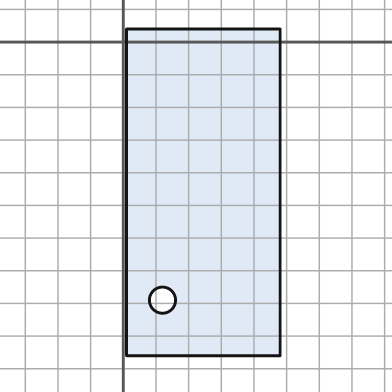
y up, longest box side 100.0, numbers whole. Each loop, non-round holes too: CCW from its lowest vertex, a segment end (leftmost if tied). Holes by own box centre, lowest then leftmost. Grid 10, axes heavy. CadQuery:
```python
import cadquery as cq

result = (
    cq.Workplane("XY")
    .moveTo(1.0, -96.0)
    .lineTo(48.0, -96.0)
    .lineTo(48.0, 4.0)
    .lineTo(1.0, 4.0)
    .close()
    .moveTo(12.0, -79.0)
    .circle(4.0)
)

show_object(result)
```